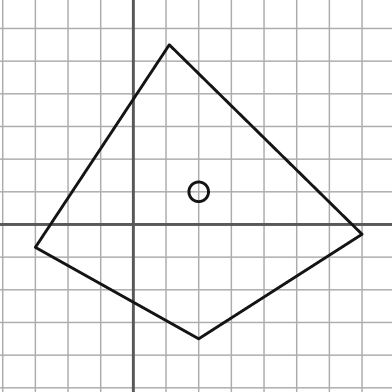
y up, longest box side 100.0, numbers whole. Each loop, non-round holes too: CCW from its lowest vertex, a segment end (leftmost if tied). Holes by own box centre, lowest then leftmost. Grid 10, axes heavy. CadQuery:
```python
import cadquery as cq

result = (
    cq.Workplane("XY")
    .moveTo(20.0, -35.0)
    .lineTo(70.0, -3.0)
    .lineTo(11.0, 55.0)
    .lineTo(-30.0, -7.0)
    .close()
    .moveTo(20.0, 10.0)
    .circle(3.0)
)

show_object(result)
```